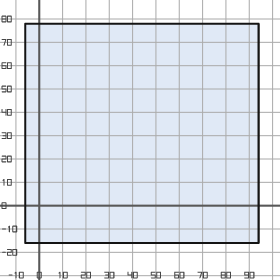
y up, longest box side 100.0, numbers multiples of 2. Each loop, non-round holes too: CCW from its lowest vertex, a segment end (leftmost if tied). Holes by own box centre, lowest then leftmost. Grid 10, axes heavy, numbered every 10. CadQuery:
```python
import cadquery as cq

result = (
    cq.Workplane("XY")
    .moveTo(-6.0, -16.0)
    .lineTo(94.0, -16.0)
    .lineTo(94.0, 78.0)
    .lineTo(-6.0, 78.0)
    .close()
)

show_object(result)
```